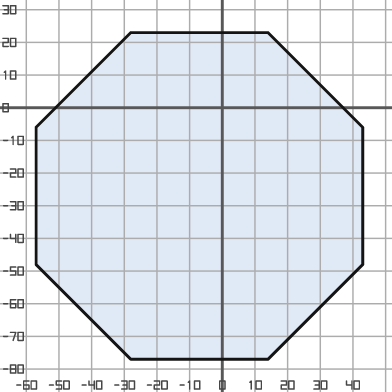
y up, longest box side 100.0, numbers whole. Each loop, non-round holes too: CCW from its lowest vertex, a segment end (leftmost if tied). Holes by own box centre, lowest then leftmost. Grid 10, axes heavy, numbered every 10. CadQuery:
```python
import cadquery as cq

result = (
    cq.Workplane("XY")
    .moveTo(-28.0, -77.0)
    .lineTo(14.0, -77.0)
    .lineTo(43.0, -48.0)
    .lineTo(43.0, -6.0)
    .lineTo(14.0, 23.0)
    .lineTo(-28.0, 23.0)
    .lineTo(-57.0, -6.0)
    .lineTo(-57.0, -48.0)
    .close()
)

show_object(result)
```